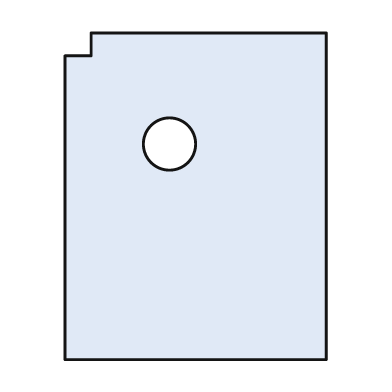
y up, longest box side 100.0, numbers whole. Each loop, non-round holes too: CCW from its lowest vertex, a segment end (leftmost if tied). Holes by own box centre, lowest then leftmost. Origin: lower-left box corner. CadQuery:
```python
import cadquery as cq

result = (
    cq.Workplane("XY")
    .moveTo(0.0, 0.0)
    .lineTo(80.0, 0.0)
    .lineTo(80.0, 100.0)
    .lineTo(8.0, 100.0)
    .lineTo(8.0, 93.0)
    .lineTo(0.0, 93.0)
    .close()
    .moveTo(32.0, 66.0)
    .circle(8.0)
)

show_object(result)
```